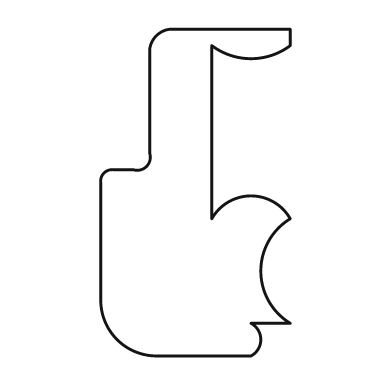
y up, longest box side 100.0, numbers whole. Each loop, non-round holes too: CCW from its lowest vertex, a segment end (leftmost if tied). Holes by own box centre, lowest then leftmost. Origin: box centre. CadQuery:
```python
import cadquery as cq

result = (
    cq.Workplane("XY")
    .moveTo(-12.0, -50.0)
    .lineTo(17.0, -50.0)
    .threePointArc((20.0, -45.0), (17.0, -40.0))
    .lineTo(29.0, -40.0)
    .threePointArc((20.0, -24.0), (29.0, -8.0))
    .threePointArc((17.0, -1.0), (5.0, -8.0))
    .lineTo(5.0, 45.0)
    .threePointArc((17.0, 41.0), (29.0, 45.0))
    .lineTo(29.0, 50.0)
    .lineTo(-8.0, 50.0)
    .threePointArc((-12.0, 48.0), (-14.0, 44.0))
    .lineTo(-14.0, 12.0)
    .threePointArc((-15.0, 8.0), (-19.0, 7.0))
    .lineTo(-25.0, 7.0)
    .threePointArc((-28.0, 6.0), (-29.0, 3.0))
    .lineTo(-29.0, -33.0)
    .threePointArc((-24.0, -45.0), (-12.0, -50.0))
    .close()
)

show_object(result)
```